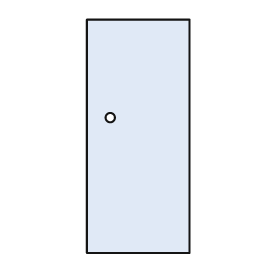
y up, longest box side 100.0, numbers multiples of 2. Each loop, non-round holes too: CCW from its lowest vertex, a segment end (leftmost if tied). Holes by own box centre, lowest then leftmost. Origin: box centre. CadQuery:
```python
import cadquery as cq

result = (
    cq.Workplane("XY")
    .moveTo(-22.0, -50.0)
    .lineTo(22.0, -50.0)
    .lineTo(22.0, 50.0)
    .lineTo(-22.0, 50.0)
    .close()
    .moveTo(-12.0, 8.0)
    .circle(2.0)
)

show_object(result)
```